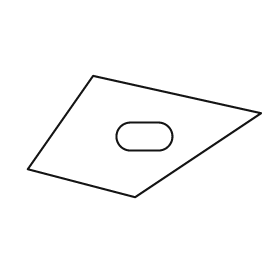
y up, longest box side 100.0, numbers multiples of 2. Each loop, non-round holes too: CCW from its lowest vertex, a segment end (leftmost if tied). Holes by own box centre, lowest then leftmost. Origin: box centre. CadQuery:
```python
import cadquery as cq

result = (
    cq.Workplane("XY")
    .moveTo(-4.0, -26.0)
    .lineTo(50.0, 10.0)
    .lineTo(-22.0, 26.0)
    .lineTo(-50.0, -14.0)
    .close()
    .moveTo(-6.0, -6.0)
    .lineTo(6.0, -6.0)
    .threePointArc((12.0, 0.0), (6.0, 6.0))
    .lineTo(-6.0, 6.0)
    .threePointArc((-12.0, 0.0), (-6.0, -6.0))
    .close()
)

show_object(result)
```